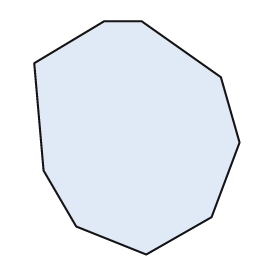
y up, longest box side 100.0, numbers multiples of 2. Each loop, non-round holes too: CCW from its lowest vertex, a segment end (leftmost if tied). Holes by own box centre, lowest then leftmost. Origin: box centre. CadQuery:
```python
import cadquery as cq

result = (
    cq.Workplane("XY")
    .moveTo(4.0, -50.0)
    .lineTo(32.0, -34.0)
    .lineTo(44.0, -2.0)
    .lineTo(36.0, 26.0)
    .lineTo(2.0, 50.0)
    .lineTo(-14.0, 50.0)
    .lineTo(-44.0, 32.0)
    .lineTo(-40.0, -14.0)
    .lineTo(-26.0, -38.0)
    .close()
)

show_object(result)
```